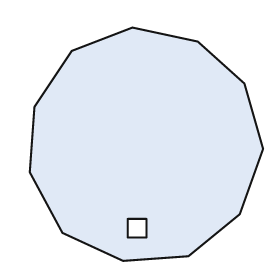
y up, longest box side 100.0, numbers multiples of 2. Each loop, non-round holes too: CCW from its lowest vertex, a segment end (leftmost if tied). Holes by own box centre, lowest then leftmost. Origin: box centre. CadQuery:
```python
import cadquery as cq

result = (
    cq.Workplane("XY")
    .moveTo(-10.0, -50.0)
    .lineTo(18.0, -48.0)
    .lineTo(40.0, -30.0)
    .lineTo(50.0, -2.0)
    .lineTo(42.0, 26.0)
    .lineTo(22.0, 44.0)
    .lineTo(-6.0, 50.0)
    .lineTo(-32.0, 40.0)
    .lineTo(-48.0, 16.0)
    .lineTo(-50.0, -12.0)
    .lineTo(-36.0, -38.0)
    .close()
    .moveTo(-8.0, -40.0)
    .lineTo(0.0, -40.0)
    .lineTo(0.0, -32.0)
    .lineTo(-8.0, -32.0)
    .close()
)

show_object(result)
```